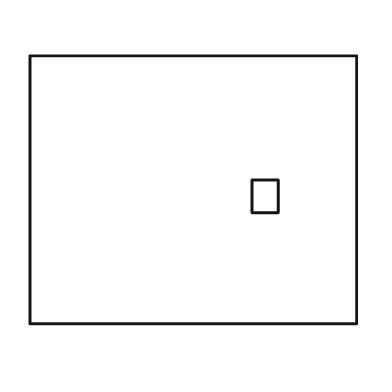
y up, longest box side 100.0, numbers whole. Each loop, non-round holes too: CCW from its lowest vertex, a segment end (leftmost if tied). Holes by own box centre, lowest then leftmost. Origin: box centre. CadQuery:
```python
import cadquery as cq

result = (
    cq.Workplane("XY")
    .moveTo(-50.0, -41.0)
    .lineTo(50.0, -41.0)
    .lineTo(50.0, 41.0)
    .lineTo(-50.0, 41.0)
    .close()
    .moveTo(18.0, -7.0)
    .lineTo(26.0, -7.0)
    .lineTo(26.0, 3.0)
    .lineTo(18.0, 3.0)
    .close()
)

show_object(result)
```